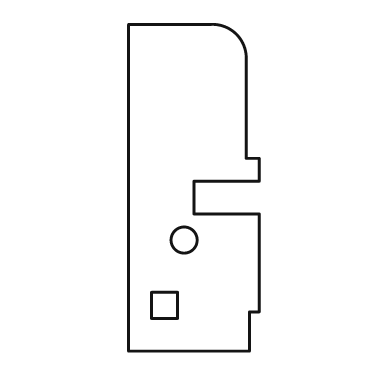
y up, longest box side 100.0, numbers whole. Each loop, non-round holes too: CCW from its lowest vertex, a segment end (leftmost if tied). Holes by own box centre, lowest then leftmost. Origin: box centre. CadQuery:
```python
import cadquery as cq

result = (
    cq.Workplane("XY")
    .moveTo(-20.0, -50.0)
    .lineTo(17.0, -50.0)
    .lineTo(17.0, -38.0)
    .lineTo(20.0, -38.0)
    .lineTo(20.0, -8.0)
    .lineTo(0.0, -8.0)
    .lineTo(0.0, 2.0)
    .lineTo(20.0, 2.0)
    .lineTo(20.0, 9.0)
    .lineTo(16.0, 9.0)
    .lineTo(16.0, 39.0)
    .threePointArc((13.0, 47.0), (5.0, 50.0))
    .lineTo(-20.0, 50.0)
    .close()
    .moveTo(-13.0, -40.0)
    .lineTo(-5.0, -40.0)
    .lineTo(-5.0, -32.0)
    .lineTo(-13.0, -32.0)
    .close()
    .moveTo(-3.0, -16.0)
    .circle(4.0)
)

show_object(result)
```